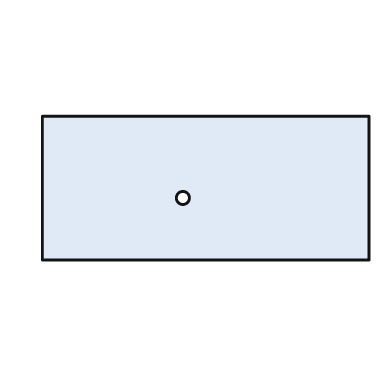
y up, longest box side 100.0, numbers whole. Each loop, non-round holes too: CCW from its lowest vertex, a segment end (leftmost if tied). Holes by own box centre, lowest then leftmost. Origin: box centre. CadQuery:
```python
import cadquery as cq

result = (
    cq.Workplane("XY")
    .moveTo(-50.0, -22.0)
    .lineTo(50.0, -22.0)
    .lineTo(50.0, 22.0)
    .lineTo(-50.0, 22.0)
    .close()
    .moveTo(-7.0, -3.0)
    .circle(2.0)
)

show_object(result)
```